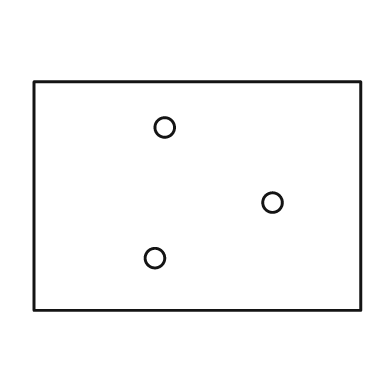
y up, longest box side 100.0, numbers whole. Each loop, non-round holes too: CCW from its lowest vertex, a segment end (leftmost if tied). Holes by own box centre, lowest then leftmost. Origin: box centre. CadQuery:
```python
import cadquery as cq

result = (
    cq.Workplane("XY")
    .moveTo(-50.0, -35.0)
    .lineTo(50.0, -35.0)
    .lineTo(50.0, 35.0)
    .lineTo(-50.0, 35.0)
    .close()
    .moveTo(-13.0, -19.0)
    .circle(3.0)
    .moveTo(23.0, -2.0)
    .circle(3.0)
    .moveTo(-10.0, 21.0)
    .circle(3.0)
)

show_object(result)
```